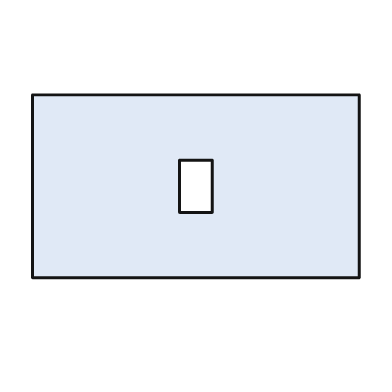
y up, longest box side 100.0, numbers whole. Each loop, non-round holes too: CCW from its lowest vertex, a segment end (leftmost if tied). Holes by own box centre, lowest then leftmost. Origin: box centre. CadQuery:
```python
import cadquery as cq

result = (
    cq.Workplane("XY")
    .moveTo(-50.0, -28.0)
    .lineTo(50.0, -28.0)
    .lineTo(50.0, 28.0)
    .lineTo(-50.0, 28.0)
    .close()
    .moveTo(-5.0, -8.0)
    .lineTo(5.0, -8.0)
    .lineTo(5.0, 8.0)
    .lineTo(-5.0, 8.0)
    .close()
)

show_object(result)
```